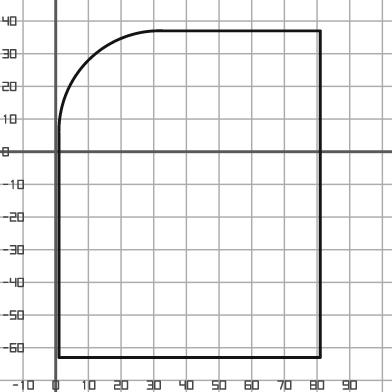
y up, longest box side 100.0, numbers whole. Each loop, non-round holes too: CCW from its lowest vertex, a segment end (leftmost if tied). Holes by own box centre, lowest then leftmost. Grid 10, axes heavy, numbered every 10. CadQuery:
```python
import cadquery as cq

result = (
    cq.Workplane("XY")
    .moveTo(1.0, -63.0)
    .lineTo(81.0, -63.0)
    .lineTo(81.0, 37.0)
    .lineTo(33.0, 37.0)
    .threePointArc((10.0, 28.0), (1.0, 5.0))
    .close()
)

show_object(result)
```